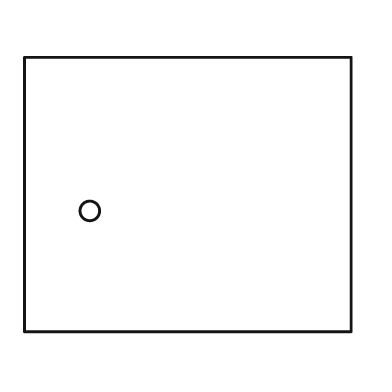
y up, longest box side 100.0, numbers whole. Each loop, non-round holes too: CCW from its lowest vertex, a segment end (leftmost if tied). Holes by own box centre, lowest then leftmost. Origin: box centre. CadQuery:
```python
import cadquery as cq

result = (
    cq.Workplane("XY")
    .moveTo(-50.0, -42.0)
    .lineTo(50.0, -42.0)
    .lineTo(50.0, 42.0)
    .lineTo(-50.0, 42.0)
    .close()
    .moveTo(-30.0, -5.0)
    .circle(3.0)
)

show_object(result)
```